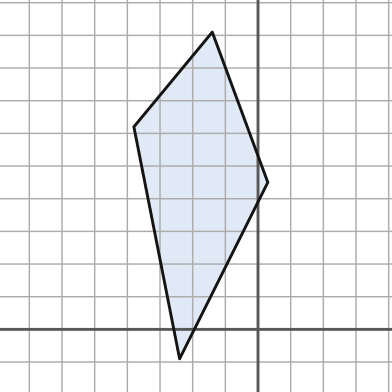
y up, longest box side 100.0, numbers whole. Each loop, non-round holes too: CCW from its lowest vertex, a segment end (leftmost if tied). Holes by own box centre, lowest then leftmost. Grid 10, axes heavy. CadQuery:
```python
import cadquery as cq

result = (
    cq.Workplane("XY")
    .moveTo(-24.0, -9.0)
    .lineTo(3.0, 45.0)
    .lineTo(-14.0, 91.0)
    .lineTo(-38.0, 62.0)
    .close()
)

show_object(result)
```